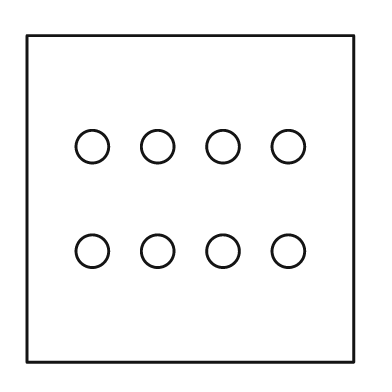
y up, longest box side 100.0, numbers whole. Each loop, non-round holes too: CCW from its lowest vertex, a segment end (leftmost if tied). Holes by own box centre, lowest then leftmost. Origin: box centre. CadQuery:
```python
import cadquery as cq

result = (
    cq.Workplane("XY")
    .moveTo(-50.0, -50.0)
    .lineTo(50.0, -50.0)
    .lineTo(50.0, 50.0)
    .lineTo(-50.0, 50.0)
    .close()
    .moveTo(-30.0, -16.0)
    .circle(5.0)
    .moveTo(-10.0, -16.0)
    .circle(5.0)
    .moveTo(10.0, -16.0)
    .circle(5.0)
    .moveTo(30.0, -16.0)
    .circle(5.0)
    .moveTo(-30.0, 16.0)
    .circle(5.0)
    .moveTo(-10.0, 16.0)
    .circle(5.0)
    .moveTo(10.0, 16.0)
    .circle(5.0)
    .moveTo(30.0, 16.0)
    .circle(5.0)
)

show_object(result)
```